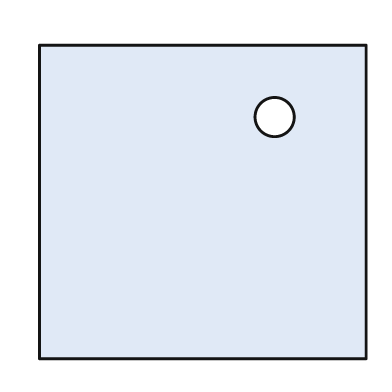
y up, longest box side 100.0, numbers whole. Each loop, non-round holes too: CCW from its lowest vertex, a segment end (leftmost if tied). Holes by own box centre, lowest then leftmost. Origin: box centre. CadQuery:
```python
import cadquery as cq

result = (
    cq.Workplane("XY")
    .moveTo(-50.0, -48.0)
    .lineTo(50.0, -48.0)
    .lineTo(50.0, 48.0)
    .lineTo(-50.0, 48.0)
    .close()
    .moveTo(22.0, 26.0)
    .circle(6.0)
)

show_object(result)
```